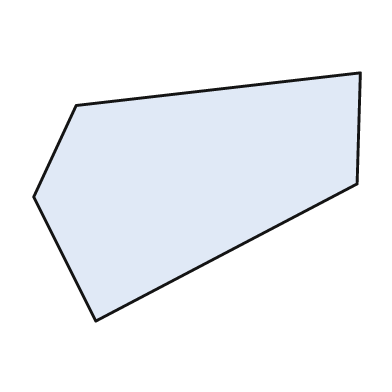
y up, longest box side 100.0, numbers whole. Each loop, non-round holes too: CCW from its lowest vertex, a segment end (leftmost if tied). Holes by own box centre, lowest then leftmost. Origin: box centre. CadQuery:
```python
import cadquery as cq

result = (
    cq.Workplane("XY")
    .moveTo(-31.0, -38.0)
    .lineTo(49.0, 4.0)
    .lineTo(50.0, 38.0)
    .lineTo(-37.0, 28.0)
    .lineTo(-50.0, 0.0)
    .close()
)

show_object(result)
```